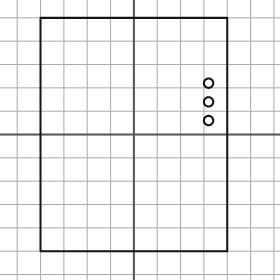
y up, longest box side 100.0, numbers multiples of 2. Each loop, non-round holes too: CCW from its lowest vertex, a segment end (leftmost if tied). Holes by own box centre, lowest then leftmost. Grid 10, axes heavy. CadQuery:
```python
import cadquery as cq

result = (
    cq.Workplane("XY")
    .moveTo(-40.0, -50.0)
    .lineTo(40.0, -50.0)
    .lineTo(40.0, 50.0)
    .lineTo(-40.0, 50.0)
    .close()
    .moveTo(32.0, 6.0)
    .circle(2.0)
    .moveTo(32.0, 14.0)
    .circle(2.0)
    .moveTo(32.0, 22.0)
    .circle(2.0)
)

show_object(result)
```